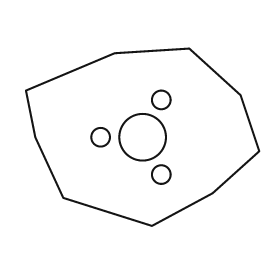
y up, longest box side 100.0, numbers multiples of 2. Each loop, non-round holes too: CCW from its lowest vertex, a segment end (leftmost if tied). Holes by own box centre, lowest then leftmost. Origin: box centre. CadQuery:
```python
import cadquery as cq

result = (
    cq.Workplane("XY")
    .moveTo(4.0, -38.0)
    .lineTo(30.0, -24.0)
    .lineTo(50.0, -6.0)
    .lineTo(42.0, 18.0)
    .lineTo(20.0, 38.0)
    .lineTo(-12.0, 36.0)
    .lineTo(-50.0, 20.0)
    .lineTo(-46.0, 0.0)
    .lineTo(-34.0, -26.0)
    .close()
    .moveTo(8.0, -16.0)
    .circle(4.0)
    .moveTo(-18.0, 0.0)
    .circle(4.0)
    .moveTo(0.0, 0.0)
    .circle(10.0)
    .moveTo(8.0, 16.0)
    .circle(4.0)
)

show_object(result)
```